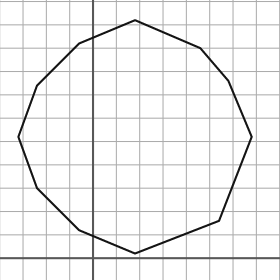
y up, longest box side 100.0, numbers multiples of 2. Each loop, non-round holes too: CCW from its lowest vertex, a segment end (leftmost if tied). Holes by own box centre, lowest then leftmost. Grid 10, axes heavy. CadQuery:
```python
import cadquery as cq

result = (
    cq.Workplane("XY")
    .moveTo(18.0, 2.0)
    .lineTo(54.0, 16.0)
    .lineTo(68.0, 52.0)
    .lineTo(58.0, 76.0)
    .lineTo(46.0, 90.0)
    .lineTo(18.0, 102.0)
    .lineTo(-6.0, 92.0)
    .lineTo(-24.0, 74.0)
    .lineTo(-32.0, 52.0)
    .lineTo(-24.0, 30.0)
    .lineTo(-6.0, 12.0)
    .close()
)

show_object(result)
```